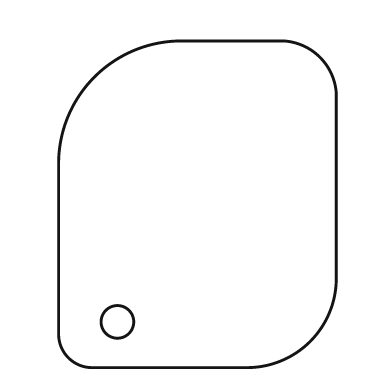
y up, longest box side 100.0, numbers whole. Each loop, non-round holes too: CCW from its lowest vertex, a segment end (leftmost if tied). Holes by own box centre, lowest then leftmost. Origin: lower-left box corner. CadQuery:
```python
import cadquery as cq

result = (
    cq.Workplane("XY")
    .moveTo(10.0, 0.0)
    .lineTo(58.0, 0.0)
    .threePointArc((77.0, 8.0), (85.0, 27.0))
    .lineTo(85.0, 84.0)
    .threePointArc((80.0, 95.0), (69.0, 100.0))
    .lineTo(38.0, 100.0)
    .threePointArc((11.0, 89.0), (0.0, 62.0))
    .lineTo(0.0, 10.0)
    .threePointArc((3.0, 3.0), (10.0, 0.0))
    .close()
    .moveTo(18.0, 14.0)
    .circle(5.0)
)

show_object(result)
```